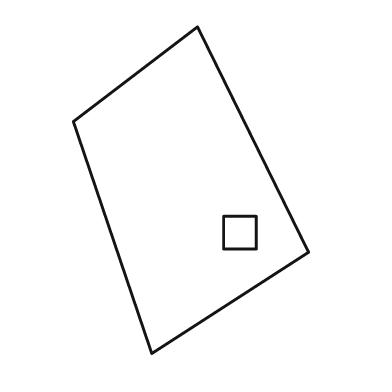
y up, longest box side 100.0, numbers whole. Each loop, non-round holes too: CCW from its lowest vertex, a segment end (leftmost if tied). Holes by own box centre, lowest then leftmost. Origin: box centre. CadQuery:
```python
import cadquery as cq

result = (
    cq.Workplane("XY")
    .moveTo(-12.0, -50.0)
    .lineTo(36.0, -19.0)
    .lineTo(2.0, 50.0)
    .lineTo(-36.0, 21.0)
    .close()
    .moveTo(10.0, -18.0)
    .lineTo(20.0, -18.0)
    .lineTo(20.0, -8.0)
    .lineTo(10.0, -8.0)
    .close()
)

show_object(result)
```